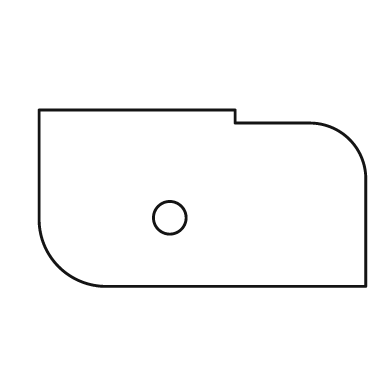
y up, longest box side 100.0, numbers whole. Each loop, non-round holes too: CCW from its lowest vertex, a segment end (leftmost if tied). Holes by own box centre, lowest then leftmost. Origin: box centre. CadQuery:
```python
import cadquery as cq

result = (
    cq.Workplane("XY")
    .moveTo(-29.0, -27.0)
    .lineTo(50.0, -27.0)
    .lineTo(50.0, 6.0)
    .threePointArc((45.0, 18.0), (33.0, 23.0))
    .lineTo(10.0, 23.0)
    .lineTo(10.0, 27.0)
    .lineTo(-50.0, 27.0)
    .lineTo(-50.0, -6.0)
    .threePointArc((-44.0, -21.0), (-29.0, -27.0))
    .close()
    .moveTo(-10.0, -6.0)
    .circle(5.0)
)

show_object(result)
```